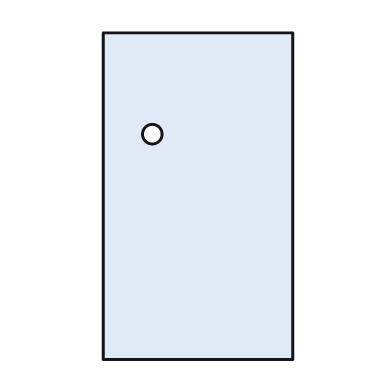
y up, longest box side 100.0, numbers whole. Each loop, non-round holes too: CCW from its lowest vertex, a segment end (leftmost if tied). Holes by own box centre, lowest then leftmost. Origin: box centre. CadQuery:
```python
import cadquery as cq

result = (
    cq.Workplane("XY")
    .moveTo(-29.0, -50.0)
    .lineTo(29.0, -50.0)
    .lineTo(29.0, 50.0)
    .lineTo(-29.0, 50.0)
    .close()
    .moveTo(-14.0, 19.0)
    .circle(3.0)
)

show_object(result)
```